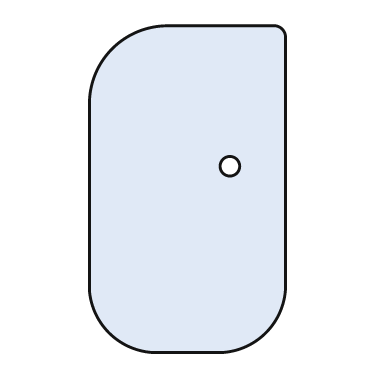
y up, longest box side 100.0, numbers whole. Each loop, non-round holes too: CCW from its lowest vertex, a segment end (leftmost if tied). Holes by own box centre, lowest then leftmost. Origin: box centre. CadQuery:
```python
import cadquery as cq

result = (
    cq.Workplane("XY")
    .moveTo(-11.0, -50.0)
    .lineTo(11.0, -50.0)
    .threePointArc((24.0, -44.0), (30.0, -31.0))
    .lineTo(30.0, 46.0)
    .threePointArc((29.0, 49.0), (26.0, 50.0))
    .lineTo(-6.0, 50.0)
    .threePointArc((-23.0, 43.0), (-30.0, 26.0))
    .lineTo(-30.0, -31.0)
    .threePointArc((-24.0, -44.0), (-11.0, -50.0))
    .close()
    .moveTo(13.0, 7.0)
    .circle(3.0)
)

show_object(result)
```